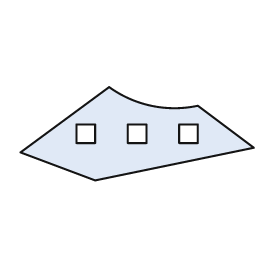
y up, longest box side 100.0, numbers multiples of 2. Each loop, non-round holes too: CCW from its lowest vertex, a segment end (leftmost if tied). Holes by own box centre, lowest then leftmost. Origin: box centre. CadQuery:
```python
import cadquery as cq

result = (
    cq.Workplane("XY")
    .moveTo(-18.0, -20.0)
    .lineTo(50.0, -6.0)
    .lineTo(26.0, 12.0)
    .threePointArc((6.0, 12.0), (-12.0, 20.0))
    .lineTo(-50.0, -8.0)
    .close()
    .moveTo(-26.0, -4.0)
    .lineTo(-18.0, -4.0)
    .lineTo(-18.0, 4.0)
    .lineTo(-26.0, 4.0)
    .close()
    .moveTo(-4.0, -4.0)
    .lineTo(4.0, -4.0)
    .lineTo(4.0, 4.0)
    .lineTo(-4.0, 4.0)
    .close()
    .moveTo(18.0, -4.0)
    .lineTo(26.0, -4.0)
    .lineTo(26.0, 4.0)
    .lineTo(18.0, 4.0)
    .close()
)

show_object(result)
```